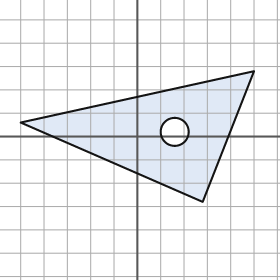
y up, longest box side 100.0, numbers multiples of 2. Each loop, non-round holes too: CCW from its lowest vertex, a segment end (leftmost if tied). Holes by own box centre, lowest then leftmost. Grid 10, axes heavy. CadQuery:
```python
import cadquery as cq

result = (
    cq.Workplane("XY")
    .moveTo(28.0, -28.0)
    .lineTo(50.0, 28.0)
    .lineTo(-50.0, 6.0)
    .close()
    .moveTo(16.0, 2.0)
    .circle(6.0)
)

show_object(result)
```